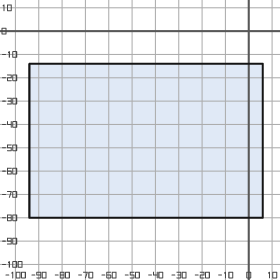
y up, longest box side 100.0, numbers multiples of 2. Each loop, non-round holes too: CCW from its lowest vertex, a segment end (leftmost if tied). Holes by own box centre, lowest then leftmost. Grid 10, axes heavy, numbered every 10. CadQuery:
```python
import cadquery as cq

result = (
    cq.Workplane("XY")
    .moveTo(-94.0, -80.0)
    .lineTo(6.0, -80.0)
    .lineTo(6.0, -14.0)
    .lineTo(-94.0, -14.0)
    .close()
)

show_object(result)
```